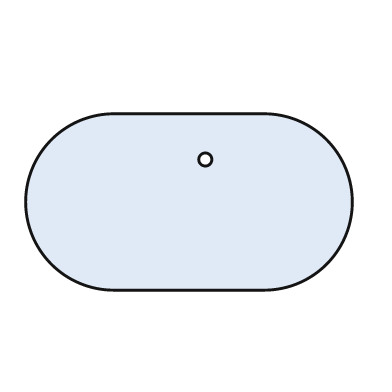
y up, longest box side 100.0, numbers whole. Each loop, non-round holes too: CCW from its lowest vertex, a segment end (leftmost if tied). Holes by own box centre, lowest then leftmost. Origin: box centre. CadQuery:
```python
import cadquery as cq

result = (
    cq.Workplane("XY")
    .moveTo(-23.0, -27.0)
    .lineTo(23.0, -27.0)
    .threePointArc((50.0, 0.0), (23.0, 27.0))
    .lineTo(-23.0, 27.0)
    .threePointArc((-50.0, 0.0), (-23.0, -27.0))
    .close()
    .moveTo(5.0, 13.0)
    .circle(2.0)
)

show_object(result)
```